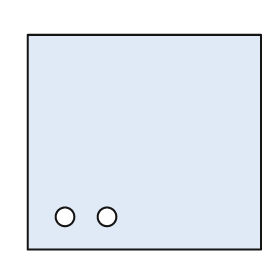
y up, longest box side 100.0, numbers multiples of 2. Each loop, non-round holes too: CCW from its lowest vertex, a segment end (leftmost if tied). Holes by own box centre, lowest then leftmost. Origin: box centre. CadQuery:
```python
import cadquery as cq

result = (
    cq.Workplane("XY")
    .moveTo(-50.0, -46.0)
    .lineTo(50.0, -46.0)
    .lineTo(50.0, 46.0)
    .lineTo(-50.0, 46.0)
    .close()
    .moveTo(-34.0, -32.0)
    .circle(4.0)
    .moveTo(-16.0, -32.0)
    .circle(4.0)
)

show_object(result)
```